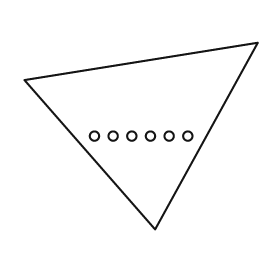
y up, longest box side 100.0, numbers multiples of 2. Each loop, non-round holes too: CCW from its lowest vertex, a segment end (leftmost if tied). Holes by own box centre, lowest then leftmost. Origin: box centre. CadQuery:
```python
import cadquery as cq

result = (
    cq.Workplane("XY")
    .moveTo(6.0, -40.0)
    .lineTo(50.0, 40.0)
    .lineTo(-50.0, 24.0)
    .close()
    .moveTo(-20.0, 0.0)
    .circle(2.0)
    .moveTo(-12.0, 0.0)
    .circle(2.0)
    .moveTo(-4.0, 0.0)
    .circle(2.0)
    .moveTo(4.0, 0.0)
    .circle(2.0)
    .moveTo(12.0, 0.0)
    .circle(2.0)
    .moveTo(20.0, 0.0)
    .circle(2.0)
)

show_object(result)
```